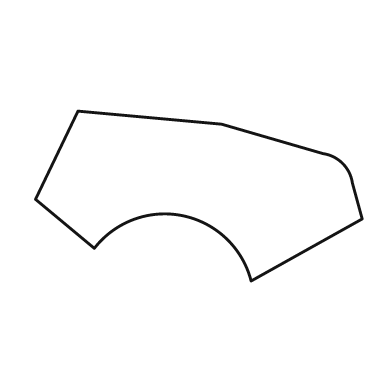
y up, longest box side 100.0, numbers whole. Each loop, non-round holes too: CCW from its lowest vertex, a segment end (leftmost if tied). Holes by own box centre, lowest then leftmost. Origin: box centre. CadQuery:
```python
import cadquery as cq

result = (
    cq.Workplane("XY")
    .moveTo(16.0, -26.0)
    .lineTo(50.0, -7.0)
    .lineTo(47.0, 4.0)
    .threePointArc((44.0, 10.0), (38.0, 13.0))
    .lineTo(7.0, 22.0)
    .lineTo(-37.0, 26.0)
    .lineTo(-50.0, -1.0)
    .lineTo(-32.0, -16.0)
    .threePointArc((-5.0, -6.0), (16.0, -26.0))
    .close()
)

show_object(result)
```